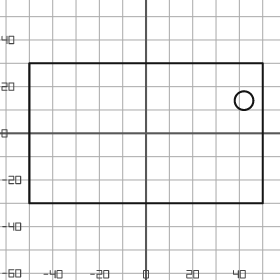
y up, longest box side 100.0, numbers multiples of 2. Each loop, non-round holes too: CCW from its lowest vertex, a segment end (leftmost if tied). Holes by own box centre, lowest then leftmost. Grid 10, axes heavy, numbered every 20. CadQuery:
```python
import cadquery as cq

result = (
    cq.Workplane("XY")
    .moveTo(-50.0, -30.0)
    .lineTo(50.0, -30.0)
    .lineTo(50.0, 30.0)
    .lineTo(-50.0, 30.0)
    .close()
    .moveTo(42.0, 14.0)
    .circle(4.0)
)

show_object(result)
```